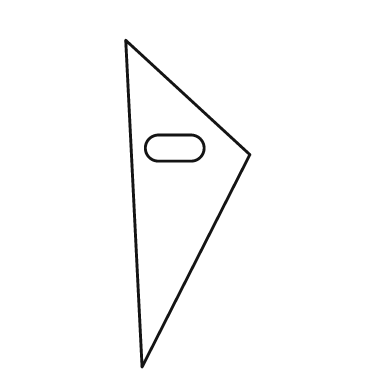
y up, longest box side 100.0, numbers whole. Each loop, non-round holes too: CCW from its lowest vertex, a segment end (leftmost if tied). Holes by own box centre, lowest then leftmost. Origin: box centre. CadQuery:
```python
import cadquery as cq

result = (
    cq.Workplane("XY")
    .moveTo(-14.0, -50.0)
    .lineTo(19.0, 15.0)
    .lineTo(-19.0, 50.0)
    .close()
    .moveTo(-9.0, 13.0)
    .lineTo(1.0, 13.0)
    .threePointArc((5.0, 17.0), (1.0, 21.0))
    .lineTo(-9.0, 21.0)
    .threePointArc((-13.0, 17.0), (-9.0, 13.0))
    .close()
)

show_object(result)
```